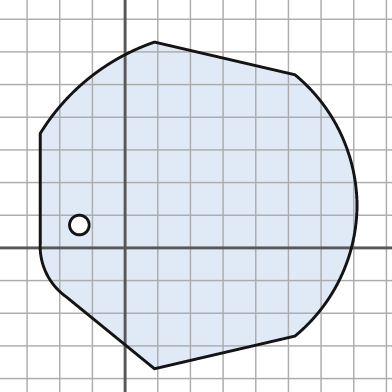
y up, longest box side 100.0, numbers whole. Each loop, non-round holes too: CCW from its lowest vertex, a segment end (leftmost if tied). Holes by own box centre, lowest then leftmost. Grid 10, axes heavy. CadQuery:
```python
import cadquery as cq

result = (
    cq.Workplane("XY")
    .moveTo(9.0, -37.0)
    .lineTo(52.0, -27.0)
    .threePointArc((66.0, -9.0), (71.0, 13.0))
    .threePointArc((66.0, 35.0), (52.0, 53.0))
    .lineTo(9.0, 63.0)
    .threePointArc((-11.0, 52.0), (-26.0, 35.0))
    .lineTo(-26.0, 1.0)
    .threePointArc((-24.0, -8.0), (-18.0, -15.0))
    .close()
    .moveTo(-14.0, 7.0)
    .circle(3.0)
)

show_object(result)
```